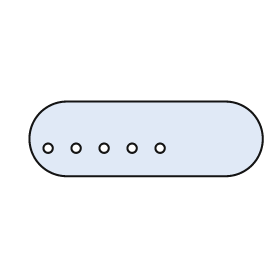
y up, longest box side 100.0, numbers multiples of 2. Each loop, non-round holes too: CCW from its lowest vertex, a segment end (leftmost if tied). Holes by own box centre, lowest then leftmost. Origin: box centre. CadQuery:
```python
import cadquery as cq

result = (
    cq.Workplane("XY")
    .moveTo(-34.0, -16.0)
    .lineTo(34.0, -16.0)
    .threePointArc((50.0, 0.0), (34.0, 16.0))
    .lineTo(-34.0, 16.0)
    .threePointArc((-50.0, 0.0), (-34.0, -16.0))
    .close()
    .moveTo(-42.0, -4.0)
    .circle(2.0)
    .moveTo(-30.0, -4.0)
    .circle(2.0)
    .moveTo(-18.0, -4.0)
    .circle(2.0)
    .moveTo(-6.0, -4.0)
    .circle(2.0)
    .moveTo(6.0, -4.0)
    .circle(2.0)
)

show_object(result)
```